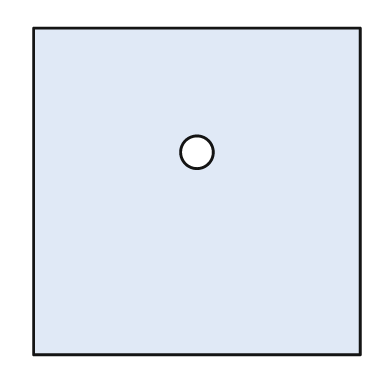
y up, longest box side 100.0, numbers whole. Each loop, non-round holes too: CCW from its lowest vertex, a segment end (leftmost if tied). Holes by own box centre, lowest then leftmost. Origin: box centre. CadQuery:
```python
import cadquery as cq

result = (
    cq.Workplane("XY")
    .moveTo(-50.0, -50.0)
    .lineTo(50.0, -50.0)
    .lineTo(50.0, 50.0)
    .lineTo(-50.0, 50.0)
    .close()
    .moveTo(0.0, 12.0)
    .circle(5.0)
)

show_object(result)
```